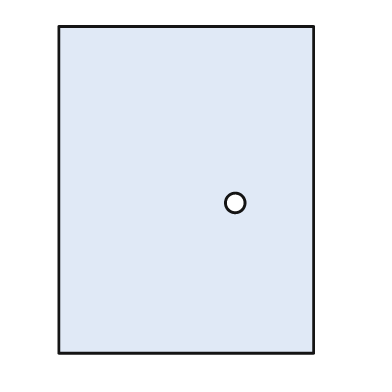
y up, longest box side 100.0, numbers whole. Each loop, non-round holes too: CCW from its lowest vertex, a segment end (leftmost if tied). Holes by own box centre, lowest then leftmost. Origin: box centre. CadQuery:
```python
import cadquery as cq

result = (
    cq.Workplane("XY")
    .moveTo(-39.0, -50.0)
    .lineTo(39.0, -50.0)
    .lineTo(39.0, 50.0)
    .lineTo(-39.0, 50.0)
    .close()
    .moveTo(15.0, -4.0)
    .circle(3.0)
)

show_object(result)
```